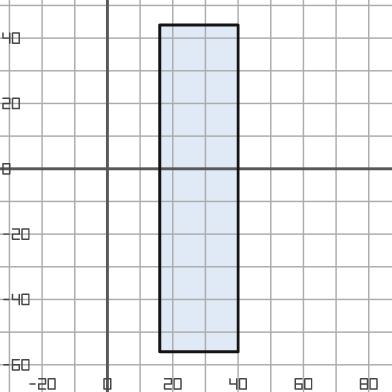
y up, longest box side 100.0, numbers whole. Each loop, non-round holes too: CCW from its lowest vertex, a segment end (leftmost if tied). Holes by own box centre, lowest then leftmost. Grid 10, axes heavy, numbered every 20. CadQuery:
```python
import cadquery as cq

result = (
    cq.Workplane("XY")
    .moveTo(16.0, -56.0)
    .lineTo(40.0, -56.0)
    .lineTo(40.0, 44.0)
    .lineTo(16.0, 44.0)
    .close()
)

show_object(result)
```